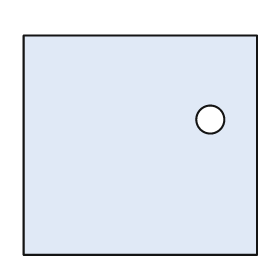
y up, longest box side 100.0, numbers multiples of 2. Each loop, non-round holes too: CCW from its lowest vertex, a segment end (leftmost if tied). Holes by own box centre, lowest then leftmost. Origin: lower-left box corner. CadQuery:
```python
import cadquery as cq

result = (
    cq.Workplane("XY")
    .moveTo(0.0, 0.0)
    .lineTo(100.0, 0.0)
    .lineTo(100.0, 94.0)
    .lineTo(0.0, 94.0)
    .close()
    .moveTo(80.0, 58.0)
    .circle(6.0)
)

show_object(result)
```